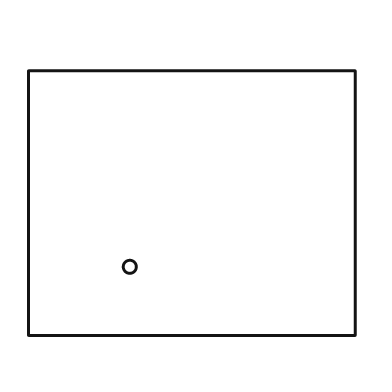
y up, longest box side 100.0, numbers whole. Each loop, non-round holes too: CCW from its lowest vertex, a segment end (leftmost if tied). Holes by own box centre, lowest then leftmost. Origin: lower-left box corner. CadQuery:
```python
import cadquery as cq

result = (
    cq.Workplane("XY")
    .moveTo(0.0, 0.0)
    .lineTo(100.0, 0.0)
    .lineTo(100.0, 81.0)
    .lineTo(0.0, 81.0)
    .close()
    .moveTo(31.0, 21.0)
    .circle(2.0)
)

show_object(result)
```